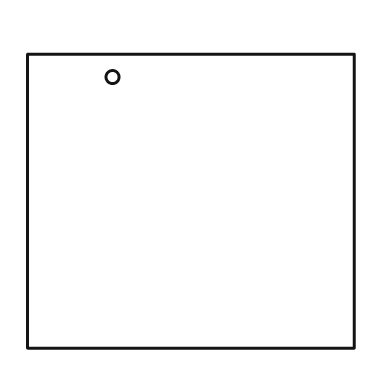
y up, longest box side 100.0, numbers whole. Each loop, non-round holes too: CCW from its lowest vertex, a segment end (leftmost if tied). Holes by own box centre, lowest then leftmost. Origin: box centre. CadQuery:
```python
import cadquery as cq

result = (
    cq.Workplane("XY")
    .moveTo(-50.0, -45.0)
    .lineTo(50.0, -45.0)
    .lineTo(50.0, 45.0)
    .lineTo(-50.0, 45.0)
    .close()
    .moveTo(-24.0, 38.0)
    .circle(2.0)
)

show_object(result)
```